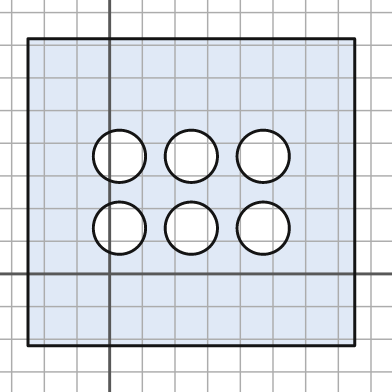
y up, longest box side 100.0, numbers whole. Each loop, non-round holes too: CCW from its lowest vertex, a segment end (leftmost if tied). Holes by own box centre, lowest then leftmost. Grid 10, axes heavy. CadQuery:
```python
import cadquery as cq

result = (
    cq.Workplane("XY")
    .moveTo(-25.0, -22.0)
    .lineTo(75.0, -22.0)
    .lineTo(75.0, 72.0)
    .lineTo(-25.0, 72.0)
    .close()
    .moveTo(3.0, 14.0)
    .circle(8.0)
    .moveTo(25.0, 14.0)
    .circle(8.0)
    .moveTo(47.0, 14.0)
    .circle(8.0)
    .moveTo(3.0, 36.0)
    .circle(8.0)
    .moveTo(25.0, 36.0)
    .circle(8.0)
    .moveTo(47.0, 36.0)
    .circle(8.0)
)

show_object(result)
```